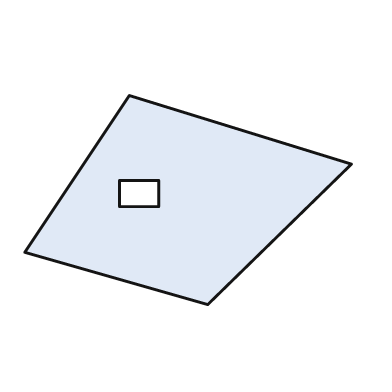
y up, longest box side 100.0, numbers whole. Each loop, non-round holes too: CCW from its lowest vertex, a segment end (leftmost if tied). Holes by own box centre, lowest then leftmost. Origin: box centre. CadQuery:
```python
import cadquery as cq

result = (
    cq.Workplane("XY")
    .moveTo(6.0, -32.0)
    .lineTo(50.0, 11.0)
    .lineTo(-18.0, 32.0)
    .lineTo(-50.0, -16.0)
    .close()
    .moveTo(-21.0, -2.0)
    .lineTo(-9.0, -2.0)
    .lineTo(-9.0, 6.0)
    .lineTo(-21.0, 6.0)
    .close()
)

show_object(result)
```